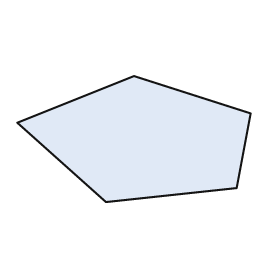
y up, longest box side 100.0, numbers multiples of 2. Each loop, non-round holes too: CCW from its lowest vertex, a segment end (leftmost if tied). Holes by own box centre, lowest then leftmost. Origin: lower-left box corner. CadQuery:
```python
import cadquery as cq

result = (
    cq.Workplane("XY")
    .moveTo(38.0, 0.0)
    .lineTo(94.0, 6.0)
    .lineTo(100.0, 38.0)
    .lineTo(50.0, 54.0)
    .lineTo(0.0, 34.0)
    .close()
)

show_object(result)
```